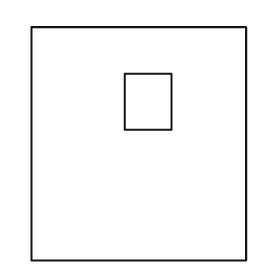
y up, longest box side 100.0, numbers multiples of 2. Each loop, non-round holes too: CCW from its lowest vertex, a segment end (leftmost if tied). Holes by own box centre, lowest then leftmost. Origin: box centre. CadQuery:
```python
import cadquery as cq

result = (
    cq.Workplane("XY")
    .moveTo(-46.0, -50.0)
    .lineTo(46.0, -50.0)
    .lineTo(46.0, 50.0)
    .lineTo(-46.0, 50.0)
    .close()
    .moveTo(-6.0, 6.0)
    .lineTo(14.0, 6.0)
    .lineTo(14.0, 30.0)
    .lineTo(-6.0, 30.0)
    .close()
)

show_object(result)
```